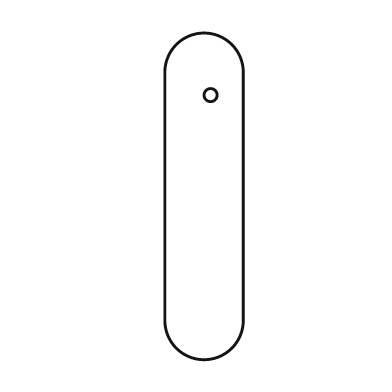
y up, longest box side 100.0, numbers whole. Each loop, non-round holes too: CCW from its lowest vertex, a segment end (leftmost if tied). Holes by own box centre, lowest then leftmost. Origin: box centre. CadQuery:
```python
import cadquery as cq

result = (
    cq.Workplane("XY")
    .moveTo(-12.0, -38.0)
    .threePointArc((0.0, -50.0), (12.0, -38.0))
    .lineTo(12.0, 38.0)
    .threePointArc((0.0, 50.0), (-12.0, 38.0))
    .close()
    .moveTo(2.0, 31.0)
    .circle(2.0)
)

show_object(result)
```